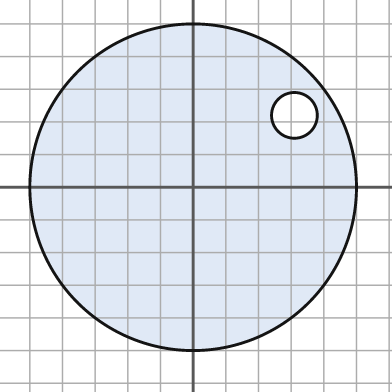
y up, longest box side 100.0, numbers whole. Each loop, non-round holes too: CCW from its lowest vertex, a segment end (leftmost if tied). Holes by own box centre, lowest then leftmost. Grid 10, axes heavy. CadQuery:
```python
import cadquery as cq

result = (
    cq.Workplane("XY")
    .moveTo(0.0, 0.0)
    .circle(50.0)
    .moveTo(31.0, 22.0)
    .circle(7.0)
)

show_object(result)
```